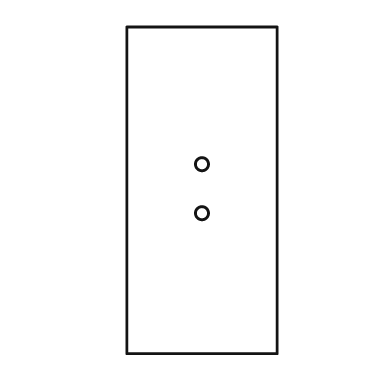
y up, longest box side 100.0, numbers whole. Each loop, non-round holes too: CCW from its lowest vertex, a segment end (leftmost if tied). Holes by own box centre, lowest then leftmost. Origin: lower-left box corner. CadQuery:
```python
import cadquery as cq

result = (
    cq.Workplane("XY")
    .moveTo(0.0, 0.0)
    .lineTo(46.0, 0.0)
    .lineTo(46.0, 100.0)
    .lineTo(0.0, 100.0)
    .close()
    .moveTo(23.0, 43.0)
    .circle(2.0)
    .moveTo(23.0, 58.0)
    .circle(2.0)
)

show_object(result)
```